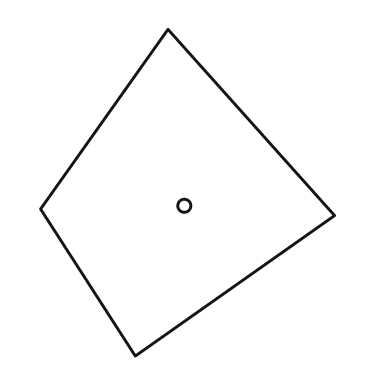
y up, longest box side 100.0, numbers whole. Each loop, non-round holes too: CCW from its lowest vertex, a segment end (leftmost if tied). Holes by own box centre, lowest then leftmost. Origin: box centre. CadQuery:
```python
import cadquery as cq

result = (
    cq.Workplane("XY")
    .moveTo(-16.0, -50.0)
    .lineTo(45.0, -7.0)
    .lineTo(-6.0, 50.0)
    .lineTo(-45.0, -5.0)
    .close()
    .moveTo(-1.0, -4.0)
    .circle(2.0)
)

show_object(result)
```